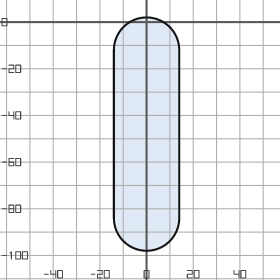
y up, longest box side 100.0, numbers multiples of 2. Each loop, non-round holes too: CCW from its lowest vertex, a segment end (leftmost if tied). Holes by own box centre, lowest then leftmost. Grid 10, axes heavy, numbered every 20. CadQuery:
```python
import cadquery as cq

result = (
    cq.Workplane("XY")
    .moveTo(-14.0, -84.0)
    .threePointArc((0.0, -98.0), (14.0, -84.0))
    .lineTo(14.0, -12.0)
    .threePointArc((0.0, 2.0), (-14.0, -12.0))
    .close()
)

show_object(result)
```